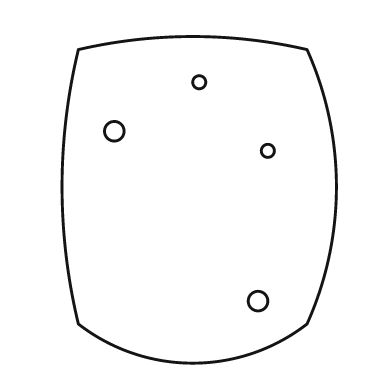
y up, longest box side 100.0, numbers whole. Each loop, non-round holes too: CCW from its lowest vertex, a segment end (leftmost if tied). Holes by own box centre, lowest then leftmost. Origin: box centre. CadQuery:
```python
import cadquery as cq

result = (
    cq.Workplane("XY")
    .moveTo(-37.0, -38.0)
    .threePointArc((-2.0, -50.0), (33.0, -38.0))
    .threePointArc((42.0, 4.0), (33.0, 46.0))
    .threePointArc((-2.0, 50.0), (-37.0, 46.0))
    .threePointArc((-42.0, 4.0), (-37.0, -38.0))
    .close()
    .moveTo(18.0, -31.0)
    .circle(3.0)
    .moveTo(21.0, 15.0)
    .circle(2.0)
    .moveTo(-26.0, 21.0)
    .circle(3.0)
    .moveTo(0.0, 36.0)
    .circle(2.0)
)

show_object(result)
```